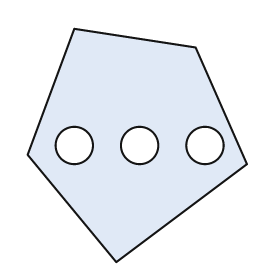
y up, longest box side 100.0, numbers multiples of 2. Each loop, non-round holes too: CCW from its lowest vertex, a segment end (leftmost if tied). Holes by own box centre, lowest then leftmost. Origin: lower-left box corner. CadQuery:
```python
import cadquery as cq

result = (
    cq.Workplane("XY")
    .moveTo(38.0, 0.0)
    .lineTo(94.0, 42.0)
    .lineTo(72.0, 92.0)
    .lineTo(20.0, 100.0)
    .lineTo(0.0, 46.0)
    .close()
    .moveTo(20.0, 50.0)
    .circle(8.0)
    .moveTo(48.0, 50.0)
    .circle(8.0)
    .moveTo(76.0, 50.0)
    .circle(8.0)
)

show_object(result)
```